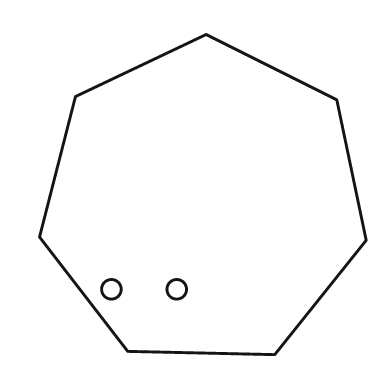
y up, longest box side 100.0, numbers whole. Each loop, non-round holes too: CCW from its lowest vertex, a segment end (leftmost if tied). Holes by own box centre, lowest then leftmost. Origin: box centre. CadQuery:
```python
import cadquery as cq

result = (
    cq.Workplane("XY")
    .moveTo(22.0, -49.0)
    .lineTo(50.0, -14.0)
    .lineTo(41.0, 29.0)
    .lineTo(1.0, 49.0)
    .lineTo(-39.0, 30.0)
    .lineTo(-50.0, -13.0)
    .lineTo(-23.0, -48.0)
    .close()
    .moveTo(-28.0, -29.0)
    .circle(3.0)
    .moveTo(-8.0, -29.0)
    .circle(3.0)
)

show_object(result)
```